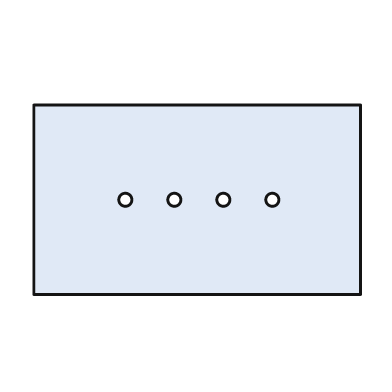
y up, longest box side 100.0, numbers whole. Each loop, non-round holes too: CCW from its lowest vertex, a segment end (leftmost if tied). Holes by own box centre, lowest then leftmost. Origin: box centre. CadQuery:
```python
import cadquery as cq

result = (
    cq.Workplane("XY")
    .moveTo(-50.0, -29.0)
    .lineTo(50.0, -29.0)
    .lineTo(50.0, 29.0)
    .lineTo(-50.0, 29.0)
    .close()
    .moveTo(-22.0, 0.0)
    .circle(2.0)
    .moveTo(-7.0, 0.0)
    .circle(2.0)
    .moveTo(8.0, 0.0)
    .circle(2.0)
    .moveTo(23.0, 0.0)
    .circle(2.0)
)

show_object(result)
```